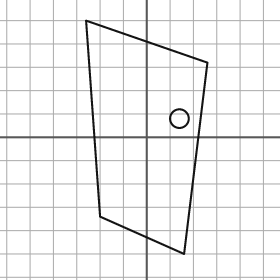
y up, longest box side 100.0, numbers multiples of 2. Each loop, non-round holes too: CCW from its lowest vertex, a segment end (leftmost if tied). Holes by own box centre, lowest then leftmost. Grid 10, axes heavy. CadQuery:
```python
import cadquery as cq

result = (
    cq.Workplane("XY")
    .moveTo(16.0, -50.0)
    .lineTo(26.0, 32.0)
    .lineTo(-26.0, 50.0)
    .lineTo(-20.0, -34.0)
    .close()
    .moveTo(14.0, 8.0)
    .circle(4.0)
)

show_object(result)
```